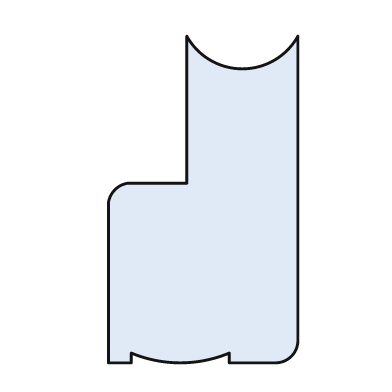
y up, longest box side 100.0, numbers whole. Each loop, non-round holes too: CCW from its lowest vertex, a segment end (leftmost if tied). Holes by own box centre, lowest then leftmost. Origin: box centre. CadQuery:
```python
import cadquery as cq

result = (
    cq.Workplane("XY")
    .moveTo(-29.0, -50.0)
    .lineTo(-22.0, -50.0)
    .lineTo(-22.0, -47.0)
    .threePointArc((-7.0, -50.0), (8.0, -47.0))
    .lineTo(8.0, -50.0)
    .lineTo(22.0, -50.0)
    .threePointArc((27.0, -48.0), (29.0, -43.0))
    .lineTo(29.0, 50.0)
    .threePointArc((12.0, 40.0), (-5.0, 50.0))
    .lineTo(-5.0, 5.0)
    .lineTo(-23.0, 5.0)
    .threePointArc((-27.0, 3.0), (-29.0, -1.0))
    .close()
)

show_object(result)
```